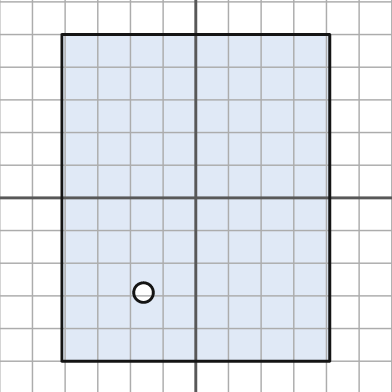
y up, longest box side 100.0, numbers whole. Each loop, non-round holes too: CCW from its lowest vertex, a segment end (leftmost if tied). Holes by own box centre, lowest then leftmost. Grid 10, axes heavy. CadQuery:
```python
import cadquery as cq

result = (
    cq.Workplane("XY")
    .moveTo(-41.0, -50.0)
    .lineTo(41.0, -50.0)
    .lineTo(41.0, 50.0)
    .lineTo(-41.0, 50.0)
    .close()
    .moveTo(-16.0, -29.0)
    .circle(3.0)
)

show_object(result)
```